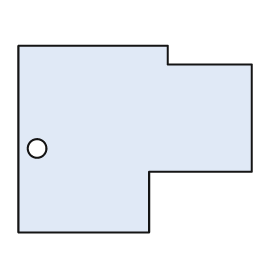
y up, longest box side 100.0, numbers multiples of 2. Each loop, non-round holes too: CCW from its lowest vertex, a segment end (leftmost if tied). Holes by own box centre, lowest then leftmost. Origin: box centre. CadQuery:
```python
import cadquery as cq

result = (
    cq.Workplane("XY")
    .moveTo(-50.0, -40.0)
    .lineTo(6.0, -40.0)
    .lineTo(6.0, -14.0)
    .lineTo(50.0, -14.0)
    .lineTo(50.0, 32.0)
    .lineTo(14.0, 32.0)
    .lineTo(14.0, 40.0)
    .lineTo(-50.0, 40.0)
    .close()
    .moveTo(-42.0, -4.0)
    .circle(4.0)
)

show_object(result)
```